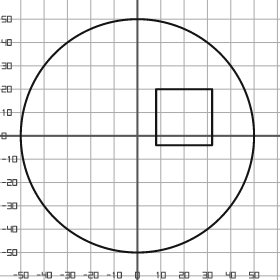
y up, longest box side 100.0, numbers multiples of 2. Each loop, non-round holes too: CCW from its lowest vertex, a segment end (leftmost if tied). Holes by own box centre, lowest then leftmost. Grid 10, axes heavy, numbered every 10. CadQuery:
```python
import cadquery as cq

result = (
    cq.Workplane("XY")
    .moveTo(0.0, 0.0)
    .circle(50.0)
    .moveTo(8.0, -4.0)
    .lineTo(32.0, -4.0)
    .lineTo(32.0, 20.0)
    .lineTo(8.0, 20.0)
    .close()
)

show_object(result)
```